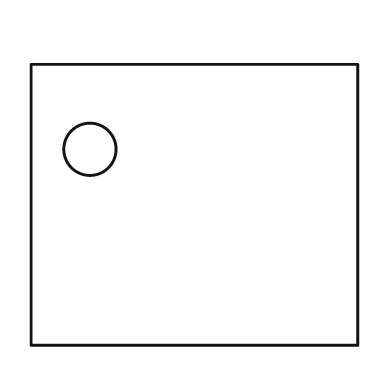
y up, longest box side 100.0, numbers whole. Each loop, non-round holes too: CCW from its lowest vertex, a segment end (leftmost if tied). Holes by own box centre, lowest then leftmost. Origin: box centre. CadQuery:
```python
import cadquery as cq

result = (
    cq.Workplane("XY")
    .moveTo(-50.0, -43.0)
    .lineTo(50.0, -43.0)
    .lineTo(50.0, 43.0)
    .lineTo(-50.0, 43.0)
    .close()
    .moveTo(-32.0, 17.0)
    .circle(8.0)
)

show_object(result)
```